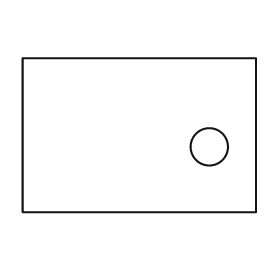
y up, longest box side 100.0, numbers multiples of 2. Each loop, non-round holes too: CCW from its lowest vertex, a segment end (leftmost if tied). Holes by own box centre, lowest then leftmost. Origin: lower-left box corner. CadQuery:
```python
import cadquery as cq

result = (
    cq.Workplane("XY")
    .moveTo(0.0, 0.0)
    .lineTo(100.0, 0.0)
    .lineTo(100.0, 66.0)
    .lineTo(0.0, 66.0)
    .close()
    .moveTo(80.0, 28.0)
    .circle(8.0)
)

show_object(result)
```